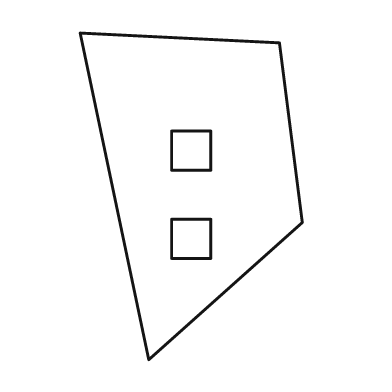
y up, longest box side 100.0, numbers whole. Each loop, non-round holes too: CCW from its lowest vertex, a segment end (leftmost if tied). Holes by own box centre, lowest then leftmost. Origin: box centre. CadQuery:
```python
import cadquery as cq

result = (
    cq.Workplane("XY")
    .moveTo(-13.0, -50.0)
    .lineTo(34.0, -8.0)
    .lineTo(27.0, 47.0)
    .lineTo(-34.0, 50.0)
    .close()
    .moveTo(-6.0, -19.0)
    .lineTo(6.0, -19.0)
    .lineTo(6.0, -7.0)
    .lineTo(-6.0, -7.0)
    .close()
    .moveTo(-6.0, 8.0)
    .lineTo(6.0, 8.0)
    .lineTo(6.0, 20.0)
    .lineTo(-6.0, 20.0)
    .close()
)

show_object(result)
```